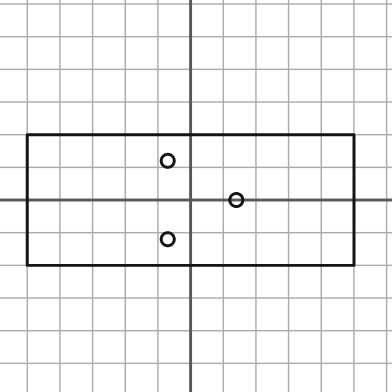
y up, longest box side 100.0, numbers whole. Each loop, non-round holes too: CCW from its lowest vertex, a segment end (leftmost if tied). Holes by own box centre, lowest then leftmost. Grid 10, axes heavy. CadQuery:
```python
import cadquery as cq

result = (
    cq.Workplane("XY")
    .moveTo(-50.0, -20.0)
    .lineTo(50.0, -20.0)
    .lineTo(50.0, 20.0)
    .lineTo(-50.0, 20.0)
    .close()
    .moveTo(-7.0, -12.0)
    .circle(2.0)
    .moveTo(14.0, 0.0)
    .circle(2.0)
    .moveTo(-7.0, 12.0)
    .circle(2.0)
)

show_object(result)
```